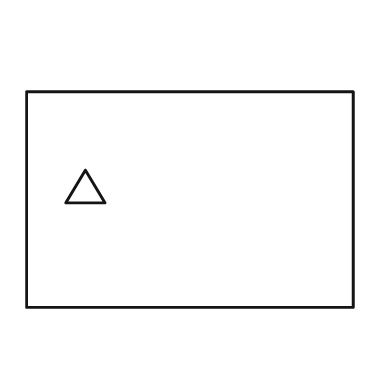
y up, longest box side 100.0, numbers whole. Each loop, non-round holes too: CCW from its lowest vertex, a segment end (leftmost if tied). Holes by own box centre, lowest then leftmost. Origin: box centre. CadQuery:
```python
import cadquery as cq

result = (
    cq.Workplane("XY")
    .moveTo(-50.0, -33.0)
    .lineTo(50.0, -33.0)
    .lineTo(50.0, 33.0)
    .lineTo(-50.0, 33.0)
    .close()
    .moveTo(-38.0, -1.0)
    .lineTo(-26.0, -1.0)
    .lineTo(-32.0, 9.0)
    .close()
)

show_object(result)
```